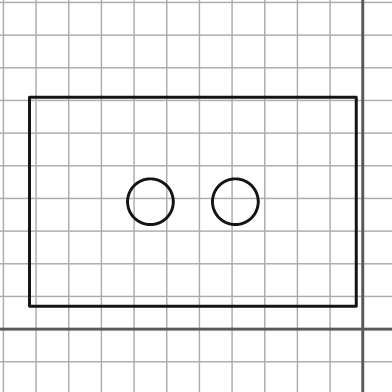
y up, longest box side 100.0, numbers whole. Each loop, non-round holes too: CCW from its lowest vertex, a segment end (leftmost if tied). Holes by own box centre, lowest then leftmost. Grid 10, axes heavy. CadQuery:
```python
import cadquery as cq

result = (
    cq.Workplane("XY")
    .moveTo(-102.0, 7.0)
    .lineTo(-2.0, 7.0)
    .lineTo(-2.0, 71.0)
    .lineTo(-102.0, 71.0)
    .close()
    .moveTo(-65.0, 39.0)
    .circle(7.0)
    .moveTo(-39.0, 39.0)
    .circle(7.0)
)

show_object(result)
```